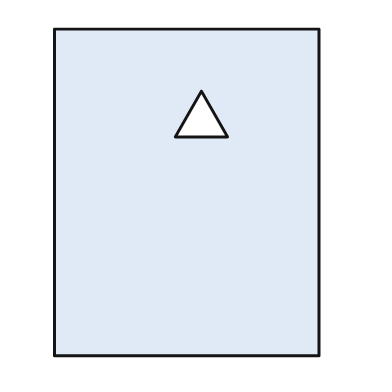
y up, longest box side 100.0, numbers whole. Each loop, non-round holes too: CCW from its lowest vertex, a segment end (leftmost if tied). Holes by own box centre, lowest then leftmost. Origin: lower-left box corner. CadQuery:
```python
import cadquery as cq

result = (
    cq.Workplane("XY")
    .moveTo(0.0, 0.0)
    .lineTo(81.0, 0.0)
    .lineTo(81.0, 100.0)
    .lineTo(0.0, 100.0)
    .close()
    .moveTo(37.0, 67.0)
    .lineTo(53.0, 67.0)
    .lineTo(45.0, 81.0)
    .close()
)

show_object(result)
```